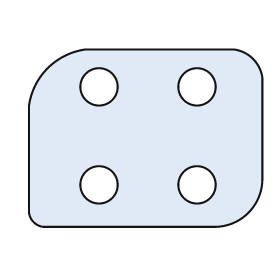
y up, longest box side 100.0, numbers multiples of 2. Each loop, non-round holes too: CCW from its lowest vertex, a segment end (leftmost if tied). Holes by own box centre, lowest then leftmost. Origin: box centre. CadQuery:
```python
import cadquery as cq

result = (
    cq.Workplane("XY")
    .moveTo(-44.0, -38.0)
    .lineTo(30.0, -38.0)
    .threePointArc((44.0, -32.0), (50.0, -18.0))
    .lineTo(50.0, 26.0)
    .threePointArc((46.0, 34.0), (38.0, 38.0))
    .lineTo(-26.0, 38.0)
    .threePointArc((-42.0, 30.0), (-50.0, 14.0))
    .lineTo(-50.0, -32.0)
    .threePointArc((-48.0, -36.0), (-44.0, -38.0))
    .close()
    .moveTo(-20.0, -20.0)
    .circle(8.0)
    .moveTo(22.0, -20.0)
    .circle(8.0)
    .moveTo(-20.0, 22.0)
    .circle(8.0)
    .moveTo(22.0, 22.0)
    .circle(8.0)
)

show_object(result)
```